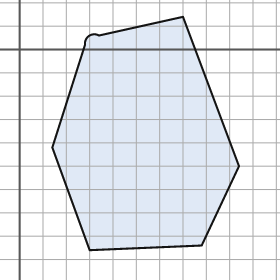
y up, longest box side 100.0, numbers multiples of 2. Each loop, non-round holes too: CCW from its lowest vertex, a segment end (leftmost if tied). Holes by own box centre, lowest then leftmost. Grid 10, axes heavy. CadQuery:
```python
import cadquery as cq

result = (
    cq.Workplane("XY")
    .moveTo(30.0, -86.0)
    .lineTo(78.0, -84.0)
    .lineTo(94.0, -50.0)
    .lineTo(70.0, 14.0)
    .lineTo(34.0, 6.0)
    .threePointArc((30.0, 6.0), (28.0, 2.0))
    .lineTo(14.0, -42.0)
    .close()
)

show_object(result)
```